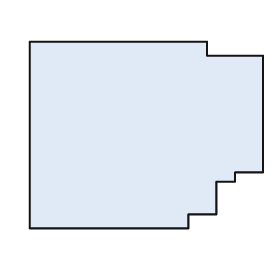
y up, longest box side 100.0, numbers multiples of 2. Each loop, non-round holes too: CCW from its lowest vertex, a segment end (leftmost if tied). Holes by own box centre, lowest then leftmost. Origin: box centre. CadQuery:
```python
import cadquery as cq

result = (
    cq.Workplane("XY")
    .moveTo(-50.0, -40.0)
    .lineTo(18.0, -40.0)
    .lineTo(18.0, -34.0)
    .lineTo(30.0, -34.0)
    .lineTo(30.0, -20.0)
    .lineTo(38.0, -20.0)
    .lineTo(38.0, -16.0)
    .lineTo(50.0, -16.0)
    .lineTo(50.0, 34.0)
    .lineTo(26.0, 34.0)
    .lineTo(26.0, 40.0)
    .lineTo(-50.0, 40.0)
    .close()
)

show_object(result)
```